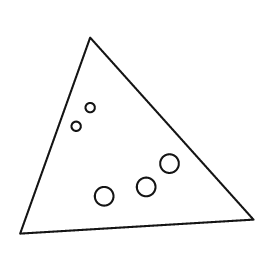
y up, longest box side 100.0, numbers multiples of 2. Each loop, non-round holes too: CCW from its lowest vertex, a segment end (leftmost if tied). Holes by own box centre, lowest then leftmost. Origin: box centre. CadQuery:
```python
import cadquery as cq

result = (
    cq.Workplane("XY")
    .moveTo(-50.0, -42.0)
    .lineTo(50.0, -36.0)
    .lineTo(-20.0, 42.0)
    .close()
    .moveTo(-14.0, -26.0)
    .circle(4.0)
    .moveTo(4.0, -22.0)
    .circle(4.0)
    .moveTo(14.0, -12.0)
    .circle(4.0)
    .moveTo(-26.0, 4.0)
    .circle(2.0)
    .moveTo(-20.0, 12.0)
    .circle(2.0)
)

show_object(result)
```